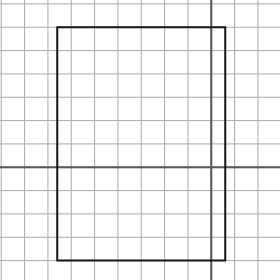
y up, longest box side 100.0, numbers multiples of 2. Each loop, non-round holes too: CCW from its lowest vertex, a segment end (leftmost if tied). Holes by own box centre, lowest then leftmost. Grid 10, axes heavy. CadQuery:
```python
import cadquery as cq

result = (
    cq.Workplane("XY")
    .moveTo(-66.0, -40.0)
    .lineTo(6.0, -40.0)
    .lineTo(6.0, 60.0)
    .lineTo(-66.0, 60.0)
    .close()
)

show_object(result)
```